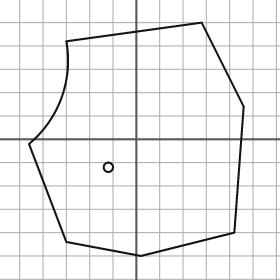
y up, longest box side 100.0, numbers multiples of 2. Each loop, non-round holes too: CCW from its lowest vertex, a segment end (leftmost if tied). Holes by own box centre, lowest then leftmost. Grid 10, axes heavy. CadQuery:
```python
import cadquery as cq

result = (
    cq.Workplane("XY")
    .moveTo(2.0, -50.0)
    .lineTo(42.0, -40.0)
    .lineTo(46.0, 14.0)
    .lineTo(28.0, 50.0)
    .lineTo(-30.0, 42.0)
    .threePointArc((-32.0, 18.0), (-46.0, -2.0))
    .lineTo(-30.0, -44.0)
    .close()
    .moveTo(-12.0, -12.0)
    .circle(2.0)
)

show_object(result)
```